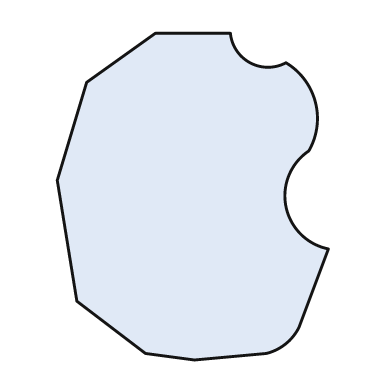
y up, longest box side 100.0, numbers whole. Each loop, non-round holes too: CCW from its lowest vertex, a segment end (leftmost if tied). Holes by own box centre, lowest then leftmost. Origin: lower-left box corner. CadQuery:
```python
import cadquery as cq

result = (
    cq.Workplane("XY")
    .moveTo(42.0, 0.0)
    .lineTo(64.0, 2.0)
    .threePointArc((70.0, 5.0), (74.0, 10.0))
    .lineTo(83.0, 34.0)
    .threePointArc((70.0, 47.0), (77.0, 64.0))
    .threePointArc((79.0, 79.0), (70.0, 91.0))
    .threePointArc((59.0, 91.0), (53.0, 100.0))
    .lineTo(30.0, 100.0)
    .lineTo(9.0, 85.0)
    .lineTo(0.0, 55.0)
    .lineTo(6.0, 18.0)
    .lineTo(27.0, 2.0)
    .close()
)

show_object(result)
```